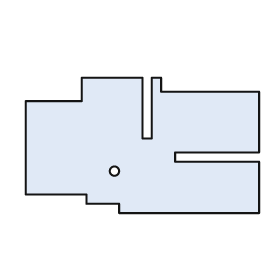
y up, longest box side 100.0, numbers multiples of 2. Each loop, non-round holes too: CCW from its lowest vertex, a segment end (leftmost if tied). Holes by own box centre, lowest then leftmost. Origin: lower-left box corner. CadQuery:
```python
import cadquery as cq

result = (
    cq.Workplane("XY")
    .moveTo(40.0, 0.0)
    .lineTo(100.0, 0.0)
    .lineTo(100.0, 22.0)
    .lineTo(64.0, 22.0)
    .lineTo(64.0, 26.0)
    .lineTo(100.0, 26.0)
    .lineTo(100.0, 52.0)
    .lineTo(58.0, 52.0)
    .lineTo(58.0, 58.0)
    .lineTo(54.0, 58.0)
    .lineTo(54.0, 32.0)
    .lineTo(50.0, 32.0)
    .lineTo(50.0, 58.0)
    .lineTo(24.0, 58.0)
    .lineTo(24.0, 48.0)
    .lineTo(0.0, 48.0)
    .lineTo(0.0, 8.0)
    .lineTo(26.0, 8.0)
    .lineTo(26.0, 4.0)
    .lineTo(40.0, 4.0)
    .close()
    .moveTo(38.0, 18.0)
    .circle(2.0)
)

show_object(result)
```